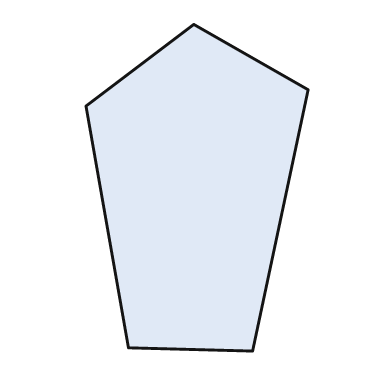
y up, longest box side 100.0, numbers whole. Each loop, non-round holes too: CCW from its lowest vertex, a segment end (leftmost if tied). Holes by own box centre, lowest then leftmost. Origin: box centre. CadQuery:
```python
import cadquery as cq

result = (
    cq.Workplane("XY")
    .moveTo(17.0, -50.0)
    .lineTo(34.0, 30.0)
    .lineTo(-1.0, 50.0)
    .lineTo(-34.0, 25.0)
    .lineTo(-21.0, -49.0)
    .close()
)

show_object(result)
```